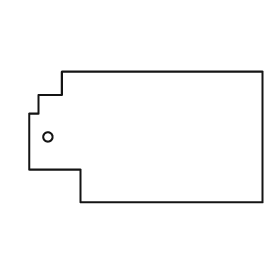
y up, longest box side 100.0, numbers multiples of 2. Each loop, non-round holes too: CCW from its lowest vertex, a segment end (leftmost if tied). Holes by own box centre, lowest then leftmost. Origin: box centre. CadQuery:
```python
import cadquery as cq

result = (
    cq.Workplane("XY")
    .moveTo(-28.0, -28.0)
    .lineTo(50.0, -28.0)
    .lineTo(50.0, 28.0)
    .lineTo(-36.0, 28.0)
    .lineTo(-36.0, 18.0)
    .lineTo(-46.0, 18.0)
    .lineTo(-46.0, 10.0)
    .lineTo(-50.0, 10.0)
    .lineTo(-50.0, -14.0)
    .lineTo(-28.0, -14.0)
    .close()
    .moveTo(-42.0, 0.0)
    .circle(2.0)
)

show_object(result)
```